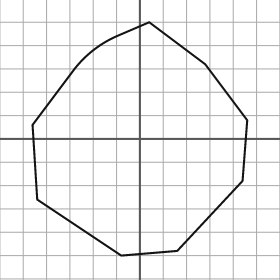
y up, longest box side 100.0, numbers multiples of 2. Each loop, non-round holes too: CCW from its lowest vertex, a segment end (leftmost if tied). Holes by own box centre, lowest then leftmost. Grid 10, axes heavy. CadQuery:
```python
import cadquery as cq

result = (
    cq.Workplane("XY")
    .moveTo(-8.0, -50.0)
    .lineTo(16.0, -48.0)
    .lineTo(44.0, -18.0)
    .lineTo(46.0, 8.0)
    .lineTo(28.0, 32.0)
    .lineTo(4.0, 50.0)
    .lineTo(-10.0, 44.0)
    .threePointArc((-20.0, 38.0), (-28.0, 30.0))
    .lineTo(-46.0, 6.0)
    .lineTo(-44.0, -26.0)
    .close()
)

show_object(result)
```